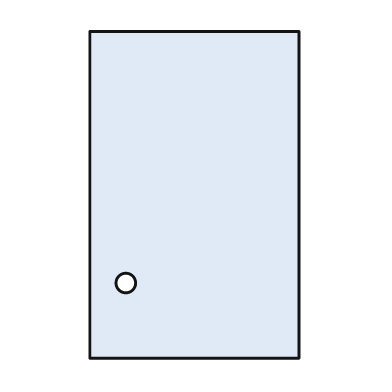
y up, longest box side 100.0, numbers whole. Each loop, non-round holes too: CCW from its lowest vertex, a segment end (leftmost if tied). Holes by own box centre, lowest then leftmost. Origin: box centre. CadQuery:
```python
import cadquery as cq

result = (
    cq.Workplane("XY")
    .moveTo(-32.0, -50.0)
    .lineTo(32.0, -50.0)
    .lineTo(32.0, 50.0)
    .lineTo(-32.0, 50.0)
    .close()
    .moveTo(-21.0, -27.0)
    .circle(3.0)
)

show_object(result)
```